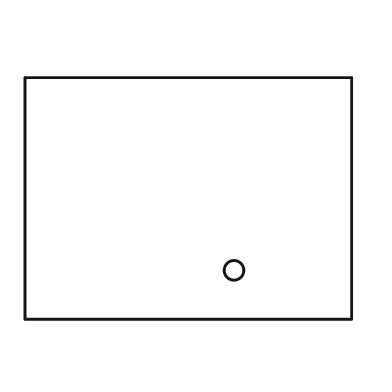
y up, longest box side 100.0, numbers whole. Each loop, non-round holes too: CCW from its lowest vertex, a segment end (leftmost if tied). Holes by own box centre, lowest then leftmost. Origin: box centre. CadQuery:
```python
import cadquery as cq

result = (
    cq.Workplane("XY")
    .moveTo(-50.0, -37.0)
    .lineTo(50.0, -37.0)
    .lineTo(50.0, 37.0)
    .lineTo(-50.0, 37.0)
    .close()
    .moveTo(14.0, -22.0)
    .circle(3.0)
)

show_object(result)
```